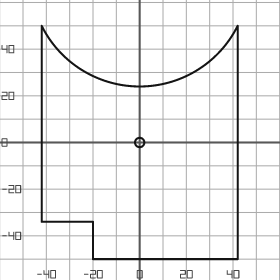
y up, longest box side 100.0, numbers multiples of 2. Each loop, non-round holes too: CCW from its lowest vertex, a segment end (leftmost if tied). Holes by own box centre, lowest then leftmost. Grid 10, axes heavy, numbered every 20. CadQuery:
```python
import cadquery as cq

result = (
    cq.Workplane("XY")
    .moveTo(-20.0, -50.0)
    .lineTo(42.0, -50.0)
    .lineTo(42.0, 50.0)
    .threePointArc((0.0, 24.0), (-42.0, 50.0))
    .lineTo(-42.0, -34.0)
    .lineTo(-20.0, -34.0)
    .close()
    .moveTo(0.0, 0.0)
    .circle(2.0)
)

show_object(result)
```